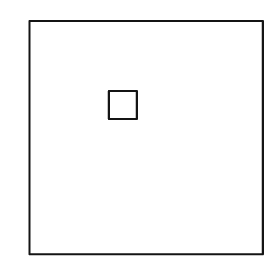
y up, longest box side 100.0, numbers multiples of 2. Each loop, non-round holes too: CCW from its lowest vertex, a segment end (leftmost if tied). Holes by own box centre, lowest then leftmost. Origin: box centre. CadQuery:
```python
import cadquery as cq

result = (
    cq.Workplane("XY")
    .moveTo(-50.0, -50.0)
    .lineTo(50.0, -50.0)
    .lineTo(50.0, 50.0)
    .lineTo(-50.0, 50.0)
    .close()
    .moveTo(-16.0, 8.0)
    .lineTo(-4.0, 8.0)
    .lineTo(-4.0, 20.0)
    .lineTo(-16.0, 20.0)
    .close()
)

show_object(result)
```